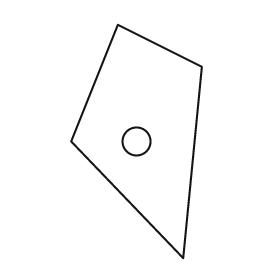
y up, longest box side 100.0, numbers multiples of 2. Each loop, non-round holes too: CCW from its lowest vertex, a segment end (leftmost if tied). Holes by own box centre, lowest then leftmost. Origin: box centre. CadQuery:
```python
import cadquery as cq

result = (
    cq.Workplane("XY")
    .moveTo(20.0, -50.0)
    .lineTo(28.0, 32.0)
    .lineTo(-8.0, 50.0)
    .lineTo(-28.0, 0.0)
    .close()
    .moveTo(0.0, 0.0)
    .circle(6.0)
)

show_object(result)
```